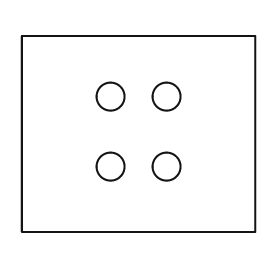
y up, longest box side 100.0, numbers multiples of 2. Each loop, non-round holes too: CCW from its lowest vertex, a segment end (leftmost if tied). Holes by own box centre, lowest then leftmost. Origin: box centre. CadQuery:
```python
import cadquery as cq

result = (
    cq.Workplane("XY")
    .moveTo(-50.0, -42.0)
    .lineTo(50.0, -42.0)
    .lineTo(50.0, 42.0)
    .lineTo(-50.0, 42.0)
    .close()
    .moveTo(-12.0, -14.0)
    .circle(6.0)
    .moveTo(12.0, -14.0)
    .circle(6.0)
    .moveTo(-12.0, 16.0)
    .circle(6.0)
    .moveTo(12.0, 16.0)
    .circle(6.0)
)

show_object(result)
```